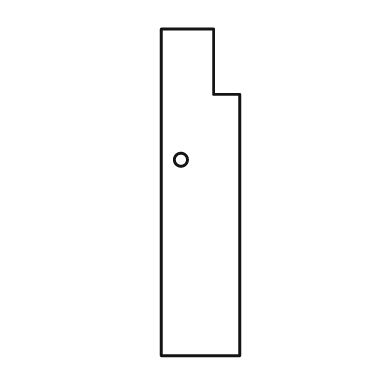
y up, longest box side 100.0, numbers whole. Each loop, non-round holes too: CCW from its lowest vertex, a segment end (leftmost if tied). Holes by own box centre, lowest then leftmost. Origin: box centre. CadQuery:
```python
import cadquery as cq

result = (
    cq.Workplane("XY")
    .moveTo(-12.0, -50.0)
    .lineTo(12.0, -50.0)
    .lineTo(12.0, 30.0)
    .lineTo(4.0, 30.0)
    .lineTo(4.0, 50.0)
    .lineTo(-12.0, 50.0)
    .close()
    .moveTo(-6.0, 10.0)
    .circle(2.0)
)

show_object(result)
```